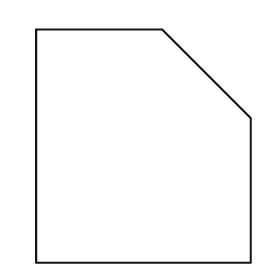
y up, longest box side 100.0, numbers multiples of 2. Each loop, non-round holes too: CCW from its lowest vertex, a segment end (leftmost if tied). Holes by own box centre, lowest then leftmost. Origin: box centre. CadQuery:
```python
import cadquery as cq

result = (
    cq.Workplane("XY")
    .moveTo(-46.0, -50.0)
    .lineTo(46.0, -50.0)
    .lineTo(46.0, 12.0)
    .lineTo(8.0, 50.0)
    .lineTo(-46.0, 50.0)
    .close()
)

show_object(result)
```